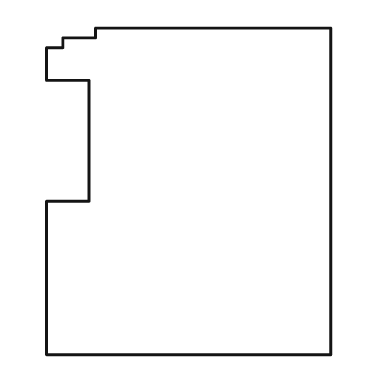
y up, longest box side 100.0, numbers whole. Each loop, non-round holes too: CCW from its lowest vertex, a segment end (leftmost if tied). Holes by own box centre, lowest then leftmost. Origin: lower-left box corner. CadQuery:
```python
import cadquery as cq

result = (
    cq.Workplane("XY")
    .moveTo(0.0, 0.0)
    .lineTo(87.0, 0.0)
    .lineTo(87.0, 100.0)
    .lineTo(15.0, 100.0)
    .lineTo(15.0, 97.0)
    .lineTo(5.0, 97.0)
    .lineTo(5.0, 94.0)
    .lineTo(0.0, 94.0)
    .lineTo(0.0, 84.0)
    .lineTo(13.0, 84.0)
    .lineTo(13.0, 47.0)
    .lineTo(0.0, 47.0)
    .close()
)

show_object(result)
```